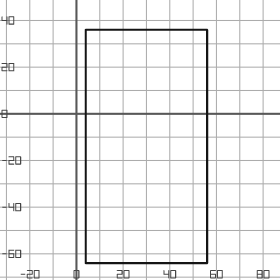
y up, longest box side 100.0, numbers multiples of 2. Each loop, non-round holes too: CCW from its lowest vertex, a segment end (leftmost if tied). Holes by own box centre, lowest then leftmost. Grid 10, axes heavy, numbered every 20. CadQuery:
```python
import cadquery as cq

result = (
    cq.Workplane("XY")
    .moveTo(4.0, -64.0)
    .lineTo(56.0, -64.0)
    .lineTo(56.0, 36.0)
    .lineTo(4.0, 36.0)
    .close()
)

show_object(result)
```